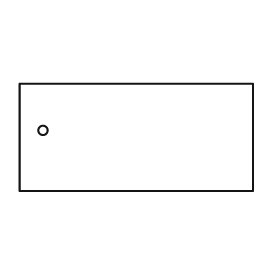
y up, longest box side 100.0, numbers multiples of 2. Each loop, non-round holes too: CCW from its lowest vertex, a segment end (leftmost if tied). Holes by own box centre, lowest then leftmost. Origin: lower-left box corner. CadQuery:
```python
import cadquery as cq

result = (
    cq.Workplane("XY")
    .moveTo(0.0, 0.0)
    .lineTo(100.0, 0.0)
    .lineTo(100.0, 46.0)
    .lineTo(0.0, 46.0)
    .close()
    .moveTo(10.0, 26.0)
    .circle(2.0)
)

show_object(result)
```